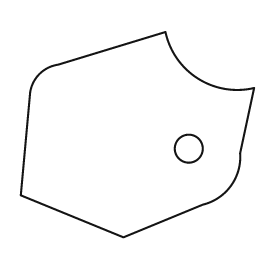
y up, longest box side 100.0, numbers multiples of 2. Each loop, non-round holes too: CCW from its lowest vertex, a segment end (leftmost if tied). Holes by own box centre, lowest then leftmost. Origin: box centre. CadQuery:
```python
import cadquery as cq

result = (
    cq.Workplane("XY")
    .moveTo(-6.0, -44.0)
    .lineTo(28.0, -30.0)
    .threePointArc((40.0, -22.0), (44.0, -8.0))
    .lineTo(50.0, 20.0)
    .threePointArc((26.0, 24.0), (12.0, 44.0))
    .lineTo(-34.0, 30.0)
    .threePointArc((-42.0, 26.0), (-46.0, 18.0))
    .lineTo(-50.0, -26.0)
    .close()
    .moveTo(22.0, -6.0)
    .circle(6.0)
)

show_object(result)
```